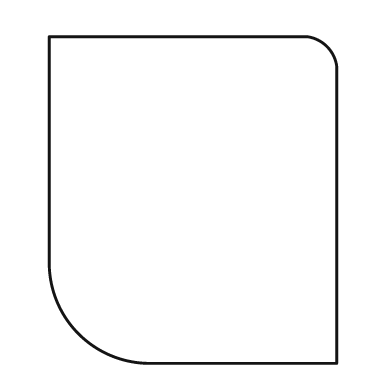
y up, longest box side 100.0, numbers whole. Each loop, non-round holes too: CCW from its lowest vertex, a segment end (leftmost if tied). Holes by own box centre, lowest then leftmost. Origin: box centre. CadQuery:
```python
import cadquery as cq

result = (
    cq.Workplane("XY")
    .moveTo(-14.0, -50.0)
    .lineTo(44.0, -50.0)
    .lineTo(44.0, 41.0)
    .threePointArc((41.0, 47.0), (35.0, 50.0))
    .lineTo(-44.0, 50.0)
    .lineTo(-44.0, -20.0)
    .threePointArc((-35.0, -41.0), (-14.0, -50.0))
    .close()
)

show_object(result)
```